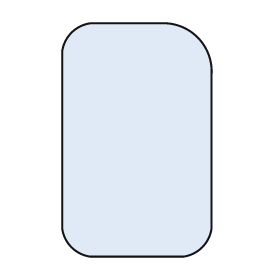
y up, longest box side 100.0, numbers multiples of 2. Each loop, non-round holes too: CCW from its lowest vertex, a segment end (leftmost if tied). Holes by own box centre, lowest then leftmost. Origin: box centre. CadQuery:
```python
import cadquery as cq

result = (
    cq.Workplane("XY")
    .moveTo(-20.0, -50.0)
    .lineTo(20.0, -50.0)
    .threePointArc((28.0, -46.0), (32.0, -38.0))
    .lineTo(32.0, 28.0)
    .threePointArc((26.0, 44.0), (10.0, 50.0))
    .lineTo(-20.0, 50.0)
    .threePointArc((-28.0, 46.0), (-32.0, 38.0))
    .lineTo(-32.0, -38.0)
    .threePointArc((-28.0, -46.0), (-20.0, -50.0))
    .close()
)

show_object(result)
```